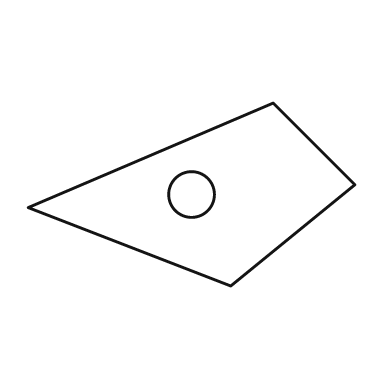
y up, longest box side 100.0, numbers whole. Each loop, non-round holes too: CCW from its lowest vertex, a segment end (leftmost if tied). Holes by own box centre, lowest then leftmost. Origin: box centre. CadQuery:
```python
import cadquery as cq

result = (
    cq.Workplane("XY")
    .moveTo(12.0, -28.0)
    .lineTo(50.0, 3.0)
    .lineTo(25.0, 28.0)
    .lineTo(-50.0, -4.0)
    .close()
    .moveTo(0.0, 0.0)
    .circle(7.0)
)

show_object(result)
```